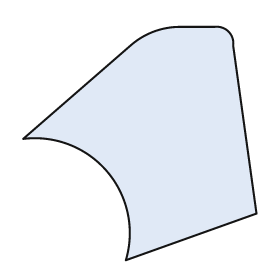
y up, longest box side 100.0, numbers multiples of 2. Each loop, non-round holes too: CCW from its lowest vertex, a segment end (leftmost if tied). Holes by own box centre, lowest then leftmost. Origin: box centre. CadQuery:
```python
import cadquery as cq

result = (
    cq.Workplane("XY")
    .moveTo(-6.0, -50.0)
    .lineTo(50.0, -30.0)
    .lineTo(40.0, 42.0)
    .threePointArc((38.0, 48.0), (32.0, 50.0))
    .lineTo(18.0, 50.0)
    .threePointArc((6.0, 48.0), (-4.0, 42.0))
    .lineTo(-50.0, 2.0)
    .threePointArc((-14.0, -12.0), (-6.0, -50.0))
    .close()
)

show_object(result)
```